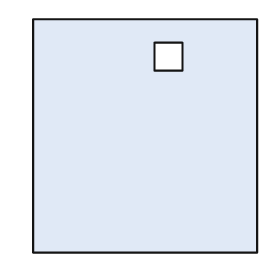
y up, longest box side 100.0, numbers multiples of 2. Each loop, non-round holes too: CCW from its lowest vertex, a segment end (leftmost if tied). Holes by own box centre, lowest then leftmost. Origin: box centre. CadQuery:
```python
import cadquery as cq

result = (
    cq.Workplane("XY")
    .moveTo(-48.0, -50.0)
    .lineTo(48.0, -50.0)
    .lineTo(48.0, 50.0)
    .lineTo(-48.0, 50.0)
    .close()
    .moveTo(4.0, 28.0)
    .lineTo(16.0, 28.0)
    .lineTo(16.0, 40.0)
    .lineTo(4.0, 40.0)
    .close()
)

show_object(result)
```